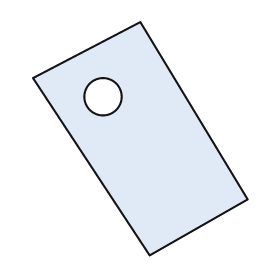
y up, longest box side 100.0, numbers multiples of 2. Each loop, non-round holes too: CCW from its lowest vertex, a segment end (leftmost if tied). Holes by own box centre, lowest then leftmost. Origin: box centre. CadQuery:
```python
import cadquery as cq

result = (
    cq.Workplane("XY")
    .moveTo(4.0, -50.0)
    .lineTo(46.0, -26.0)
    .lineTo(0.0, 50.0)
    .lineTo(-46.0, 26.0)
    .close()
    .moveTo(-16.0, 18.0)
    .circle(8.0)
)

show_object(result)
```